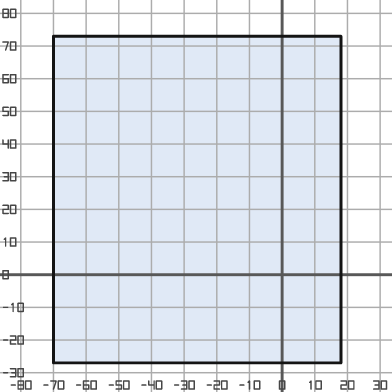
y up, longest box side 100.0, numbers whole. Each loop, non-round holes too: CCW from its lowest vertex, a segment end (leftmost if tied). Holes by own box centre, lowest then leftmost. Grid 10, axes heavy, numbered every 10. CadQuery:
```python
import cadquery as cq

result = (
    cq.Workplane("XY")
    .moveTo(-70.0, -27.0)
    .lineTo(18.0, -27.0)
    .lineTo(18.0, 73.0)
    .lineTo(-70.0, 73.0)
    .close()
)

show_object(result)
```